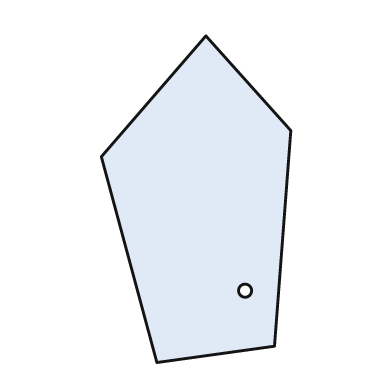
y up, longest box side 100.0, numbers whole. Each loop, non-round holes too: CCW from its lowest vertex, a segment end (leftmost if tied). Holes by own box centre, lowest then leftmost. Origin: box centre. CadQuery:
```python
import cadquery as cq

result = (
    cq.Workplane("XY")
    .moveTo(-12.0, -50.0)
    .lineTo(24.0, -45.0)
    .lineTo(29.0, 21.0)
    .lineTo(3.0, 50.0)
    .lineTo(-29.0, 13.0)
    .close()
    .moveTo(15.0, -28.0)
    .circle(2.0)
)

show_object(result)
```